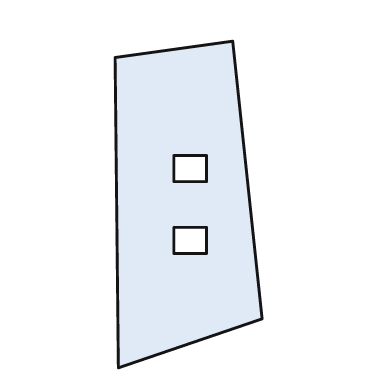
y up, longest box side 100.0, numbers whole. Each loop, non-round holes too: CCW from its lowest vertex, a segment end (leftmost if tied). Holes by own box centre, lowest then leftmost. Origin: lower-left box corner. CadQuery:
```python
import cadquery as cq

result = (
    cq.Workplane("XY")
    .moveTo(1.0, 0.0)
    .lineTo(45.0, 15.0)
    .lineTo(36.0, 100.0)
    .lineTo(0.0, 95.0)
    .close()
    .moveTo(18.0, 35.0)
    .lineTo(28.0, 35.0)
    .lineTo(28.0, 43.0)
    .lineTo(18.0, 43.0)
    .close()
    .moveTo(18.0, 57.0)
    .lineTo(28.0, 57.0)
    .lineTo(28.0, 65.0)
    .lineTo(18.0, 65.0)
    .close()
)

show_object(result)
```